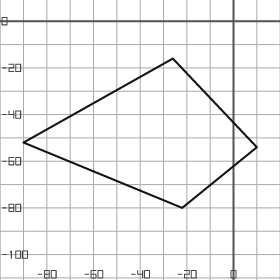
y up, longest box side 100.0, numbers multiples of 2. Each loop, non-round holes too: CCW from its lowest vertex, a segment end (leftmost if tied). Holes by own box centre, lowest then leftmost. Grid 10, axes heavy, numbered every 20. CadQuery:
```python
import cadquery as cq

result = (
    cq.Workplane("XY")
    .moveTo(-22.0, -80.0)
    .lineTo(10.0, -54.0)
    .lineTo(-26.0, -16.0)
    .lineTo(-90.0, -52.0)
    .close()
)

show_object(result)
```